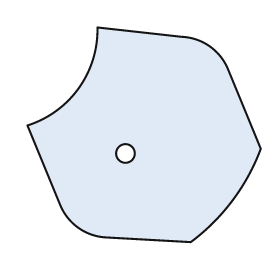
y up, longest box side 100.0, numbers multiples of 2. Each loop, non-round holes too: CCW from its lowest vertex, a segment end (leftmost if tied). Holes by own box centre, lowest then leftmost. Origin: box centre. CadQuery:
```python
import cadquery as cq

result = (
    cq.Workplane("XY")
    .moveTo(20.0, -46.0)
    .threePointArc((38.0, -28.0), (50.0, -6.0))
    .lineTo(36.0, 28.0)
    .threePointArc((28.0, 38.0), (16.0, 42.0))
    .lineTo(-20.0, 46.0)
    .threePointArc((-28.0, 20.0), (-50.0, 4.0))
    .lineTo(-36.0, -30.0)
    .threePointArc((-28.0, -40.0), (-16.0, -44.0))
    .close()
    .moveTo(-8.0, -8.0)
    .circle(4.0)
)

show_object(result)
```